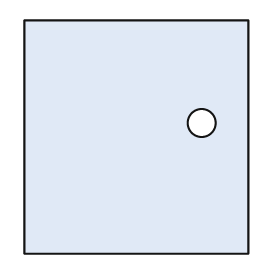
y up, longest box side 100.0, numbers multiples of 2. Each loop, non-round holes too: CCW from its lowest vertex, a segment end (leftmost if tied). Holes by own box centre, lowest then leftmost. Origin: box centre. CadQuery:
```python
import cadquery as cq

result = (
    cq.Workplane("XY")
    .moveTo(-48.0, -50.0)
    .lineTo(48.0, -50.0)
    .lineTo(48.0, 50.0)
    .lineTo(-48.0, 50.0)
    .close()
    .moveTo(28.0, 6.0)
    .circle(6.0)
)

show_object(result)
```